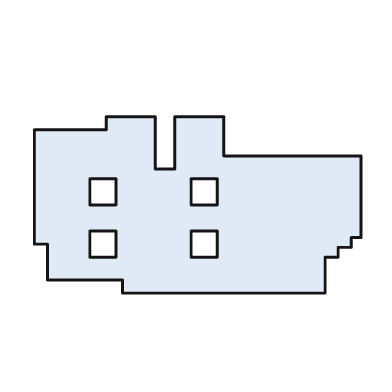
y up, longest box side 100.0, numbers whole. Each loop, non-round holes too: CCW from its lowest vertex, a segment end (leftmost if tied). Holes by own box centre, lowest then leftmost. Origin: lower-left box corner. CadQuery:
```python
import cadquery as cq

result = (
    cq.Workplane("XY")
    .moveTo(27.0, 0.0)
    .lineTo(89.0, 0.0)
    .lineTo(89.0, 11.0)
    .lineTo(93.0, 11.0)
    .lineTo(93.0, 14.0)
    .lineTo(97.0, 14.0)
    .lineTo(97.0, 17.0)
    .lineTo(100.0, 17.0)
    .lineTo(100.0, 42.0)
    .lineTo(58.0, 42.0)
    .lineTo(58.0, 54.0)
    .lineTo(43.0, 54.0)
    .lineTo(43.0, 38.0)
    .lineTo(37.0, 38.0)
    .lineTo(37.0, 54.0)
    .lineTo(22.0, 54.0)
    .lineTo(22.0, 50.0)
    .lineTo(0.0, 50.0)
    .lineTo(0.0, 15.0)
    .lineTo(4.0, 15.0)
    .lineTo(4.0, 4.0)
    .lineTo(27.0, 4.0)
    .close()
    .moveTo(17.0, 11.0)
    .lineTo(25.0, 11.0)
    .lineTo(25.0, 19.0)
    .lineTo(17.0, 19.0)
    .close()
    .moveTo(48.0, 11.0)
    .lineTo(56.0, 11.0)
    .lineTo(56.0, 19.0)
    .lineTo(48.0, 19.0)
    .close()
    .moveTo(17.0, 27.0)
    .lineTo(25.0, 27.0)
    .lineTo(25.0, 35.0)
    .lineTo(17.0, 35.0)
    .close()
    .moveTo(48.0, 27.0)
    .lineTo(56.0, 27.0)
    .lineTo(56.0, 35.0)
    .lineTo(48.0, 35.0)
    .close()
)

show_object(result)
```